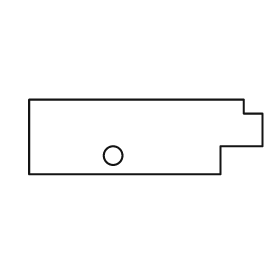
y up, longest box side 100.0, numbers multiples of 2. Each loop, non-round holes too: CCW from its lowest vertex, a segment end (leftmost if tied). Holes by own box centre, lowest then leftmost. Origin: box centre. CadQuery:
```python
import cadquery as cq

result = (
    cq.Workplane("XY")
    .moveTo(-50.0, -16.0)
    .lineTo(32.0, -16.0)
    .lineTo(32.0, -4.0)
    .lineTo(50.0, -4.0)
    .lineTo(50.0, 10.0)
    .lineTo(42.0, 10.0)
    .lineTo(42.0, 16.0)
    .lineTo(-50.0, 16.0)
    .close()
    .moveTo(-14.0, -8.0)
    .circle(4.0)
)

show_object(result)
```